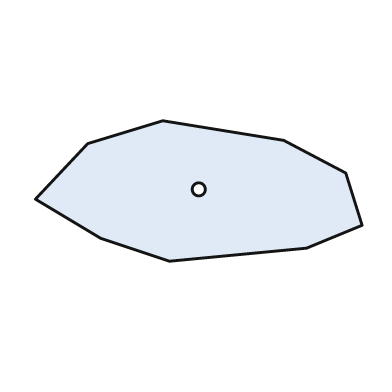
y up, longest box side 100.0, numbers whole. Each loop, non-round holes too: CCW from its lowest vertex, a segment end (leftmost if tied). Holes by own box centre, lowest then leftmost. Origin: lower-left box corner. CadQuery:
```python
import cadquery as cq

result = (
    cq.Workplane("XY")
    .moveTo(41.0, 0.0)
    .lineTo(83.0, 4.0)
    .lineTo(100.0, 11.0)
    .lineTo(95.0, 27.0)
    .lineTo(76.0, 37.0)
    .lineTo(39.0, 43.0)
    .lineTo(16.0, 36.0)
    .lineTo(0.0, 19.0)
    .lineTo(20.0, 7.0)
    .close()
    .moveTo(50.0, 22.0)
    .circle(2.0)
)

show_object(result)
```